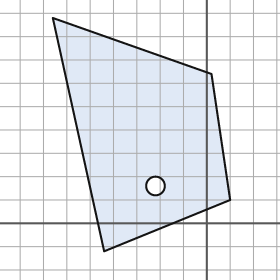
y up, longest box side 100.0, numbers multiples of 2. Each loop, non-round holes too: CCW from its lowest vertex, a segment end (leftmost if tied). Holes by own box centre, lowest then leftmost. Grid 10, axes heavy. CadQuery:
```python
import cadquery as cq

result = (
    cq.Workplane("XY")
    .moveTo(-44.0, -12.0)
    .lineTo(10.0, 10.0)
    .lineTo(2.0, 64.0)
    .lineTo(-66.0, 88.0)
    .close()
    .moveTo(-22.0, 16.0)
    .circle(4.0)
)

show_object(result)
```